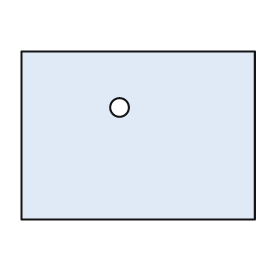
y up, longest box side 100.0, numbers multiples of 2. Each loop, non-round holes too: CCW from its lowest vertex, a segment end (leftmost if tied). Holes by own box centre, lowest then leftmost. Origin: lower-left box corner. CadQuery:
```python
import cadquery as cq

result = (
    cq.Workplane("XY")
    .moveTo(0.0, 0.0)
    .lineTo(100.0, 0.0)
    .lineTo(100.0, 72.0)
    .lineTo(0.0, 72.0)
    .close()
    .moveTo(42.0, 48.0)
    .circle(4.0)
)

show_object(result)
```